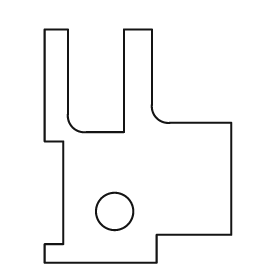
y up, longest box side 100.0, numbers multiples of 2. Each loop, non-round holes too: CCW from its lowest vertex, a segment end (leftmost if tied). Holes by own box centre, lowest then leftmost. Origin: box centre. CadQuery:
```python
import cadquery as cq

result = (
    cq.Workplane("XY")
    .moveTo(-40.0, -50.0)
    .lineTo(8.0, -50.0)
    .lineTo(8.0, -38.0)
    .lineTo(40.0, -38.0)
    .lineTo(40.0, 10.0)
    .lineTo(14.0, 10.0)
    .threePointArc((8.0, 12.0), (6.0, 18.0))
    .lineTo(6.0, 50.0)
    .lineTo(-6.0, 50.0)
    .lineTo(-6.0, 6.0)
    .lineTo(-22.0, 6.0)
    .threePointArc((-28.0, 8.0), (-30.0, 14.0))
    .lineTo(-30.0, 50.0)
    .lineTo(-40.0, 50.0)
    .lineTo(-40.0, 2.0)
    .lineTo(-32.0, 2.0)
    .lineTo(-32.0, -42.0)
    .lineTo(-40.0, -42.0)
    .close()
    .moveTo(-10.0, -28.0)
    .circle(8.0)
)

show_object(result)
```